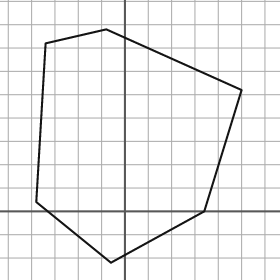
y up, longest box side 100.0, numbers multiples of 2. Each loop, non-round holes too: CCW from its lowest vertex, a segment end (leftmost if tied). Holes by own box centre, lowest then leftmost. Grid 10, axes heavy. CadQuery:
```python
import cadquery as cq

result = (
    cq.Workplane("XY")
    .moveTo(-6.0, -22.0)
    .lineTo(34.0, 0.0)
    .lineTo(50.0, 52.0)
    .lineTo(-8.0, 78.0)
    .lineTo(-34.0, 72.0)
    .lineTo(-38.0, 4.0)
    .close()
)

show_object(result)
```